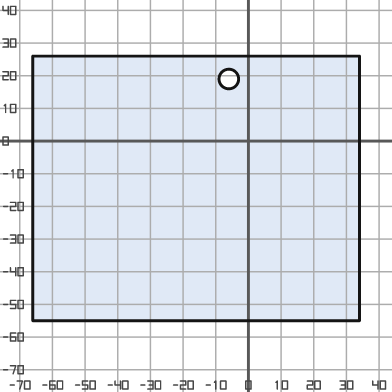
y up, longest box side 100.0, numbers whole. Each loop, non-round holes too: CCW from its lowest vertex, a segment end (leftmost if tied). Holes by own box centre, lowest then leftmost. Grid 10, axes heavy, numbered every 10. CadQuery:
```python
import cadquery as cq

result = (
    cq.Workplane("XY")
    .moveTo(-66.0, -55.0)
    .lineTo(34.0, -55.0)
    .lineTo(34.0, 26.0)
    .lineTo(-66.0, 26.0)
    .close()
    .moveTo(-6.0, 19.0)
    .circle(3.0)
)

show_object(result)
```